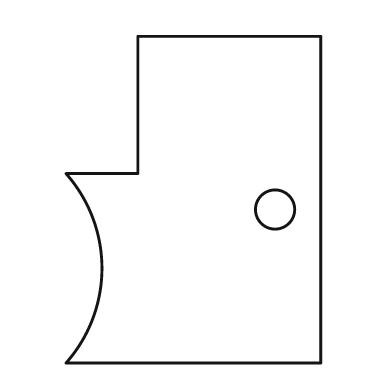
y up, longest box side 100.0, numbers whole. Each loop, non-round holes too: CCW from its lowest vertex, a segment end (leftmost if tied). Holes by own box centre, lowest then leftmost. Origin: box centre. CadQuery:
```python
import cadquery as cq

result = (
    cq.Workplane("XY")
    .moveTo(-39.0, -50.0)
    .lineTo(39.0, -50.0)
    .lineTo(39.0, 50.0)
    .lineTo(-17.0, 50.0)
    .lineTo(-17.0, 8.0)
    .lineTo(-39.0, 8.0)
    .threePointArc((-28.0, -21.0), (-39.0, -50.0))
    .close()
    .moveTo(25.0, -3.0)
    .circle(6.0)
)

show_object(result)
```